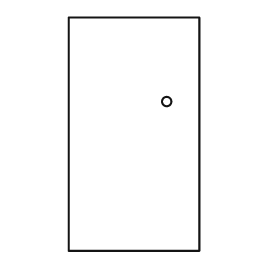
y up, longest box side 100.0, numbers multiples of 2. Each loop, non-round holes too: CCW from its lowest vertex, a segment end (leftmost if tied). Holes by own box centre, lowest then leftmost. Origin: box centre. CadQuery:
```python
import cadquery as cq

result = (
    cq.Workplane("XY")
    .moveTo(-28.0, -50.0)
    .lineTo(28.0, -50.0)
    .lineTo(28.0, 50.0)
    .lineTo(-28.0, 50.0)
    .close()
    .moveTo(14.0, 14.0)
    .circle(2.0)
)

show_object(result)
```